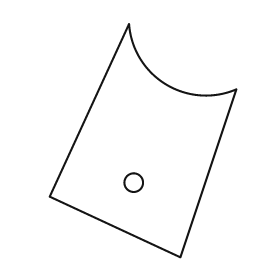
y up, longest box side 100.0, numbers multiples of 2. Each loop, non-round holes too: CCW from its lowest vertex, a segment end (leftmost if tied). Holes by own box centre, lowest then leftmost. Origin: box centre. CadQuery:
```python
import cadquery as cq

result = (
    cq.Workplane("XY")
    .moveTo(16.0, -50.0)
    .lineTo(40.0, 22.0)
    .threePointArc((10.0, 24.0), (-6.0, 50.0))
    .lineTo(-40.0, -24.0)
    .close()
    .moveTo(-4.0, -18.0)
    .circle(4.0)
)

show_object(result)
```